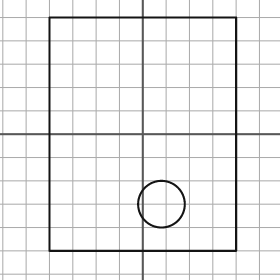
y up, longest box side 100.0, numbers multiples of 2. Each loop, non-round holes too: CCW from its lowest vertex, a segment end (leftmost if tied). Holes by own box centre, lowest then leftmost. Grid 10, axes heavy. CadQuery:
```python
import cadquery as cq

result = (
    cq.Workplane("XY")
    .moveTo(-40.0, -50.0)
    .lineTo(40.0, -50.0)
    .lineTo(40.0, 50.0)
    .lineTo(-40.0, 50.0)
    .close()
    .moveTo(8.0, -30.0)
    .circle(10.0)
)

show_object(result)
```